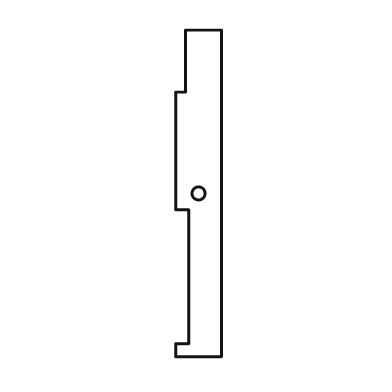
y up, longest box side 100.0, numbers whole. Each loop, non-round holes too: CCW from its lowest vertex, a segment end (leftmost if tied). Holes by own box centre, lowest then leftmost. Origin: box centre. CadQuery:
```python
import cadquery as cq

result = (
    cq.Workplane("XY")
    .moveTo(-7.0, -50.0)
    .lineTo(7.0, -50.0)
    .lineTo(7.0, 50.0)
    .lineTo(-4.0, 50.0)
    .lineTo(-4.0, 31.0)
    .lineTo(-7.0, 31.0)
    .lineTo(-7.0, -5.0)
    .lineTo(-3.0, -5.0)
    .lineTo(-3.0, -46.0)
    .lineTo(-7.0, -46.0)
    .close()
    .moveTo(0.0, 0.0)
    .circle(2.0)
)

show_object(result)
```